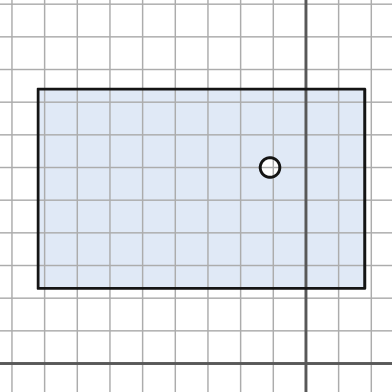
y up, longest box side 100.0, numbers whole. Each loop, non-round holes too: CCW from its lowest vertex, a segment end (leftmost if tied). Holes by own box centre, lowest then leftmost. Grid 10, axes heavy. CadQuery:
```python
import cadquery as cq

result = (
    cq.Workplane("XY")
    .moveTo(-82.0, 23.0)
    .lineTo(18.0, 23.0)
    .lineTo(18.0, 84.0)
    .lineTo(-82.0, 84.0)
    .close()
    .moveTo(-11.0, 60.0)
    .circle(3.0)
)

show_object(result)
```